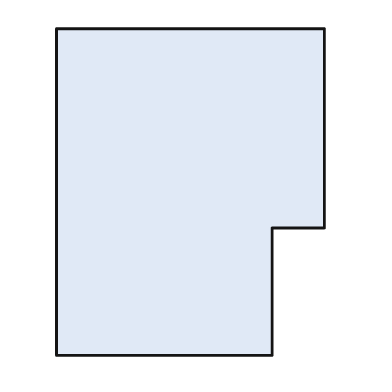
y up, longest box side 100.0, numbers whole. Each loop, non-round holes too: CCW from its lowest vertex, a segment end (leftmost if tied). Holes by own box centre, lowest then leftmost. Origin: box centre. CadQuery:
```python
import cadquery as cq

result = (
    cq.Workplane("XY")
    .moveTo(-41.0, -50.0)
    .lineTo(25.0, -50.0)
    .lineTo(25.0, -11.0)
    .lineTo(41.0, -11.0)
    .lineTo(41.0, 50.0)
    .lineTo(-41.0, 50.0)
    .close()
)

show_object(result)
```